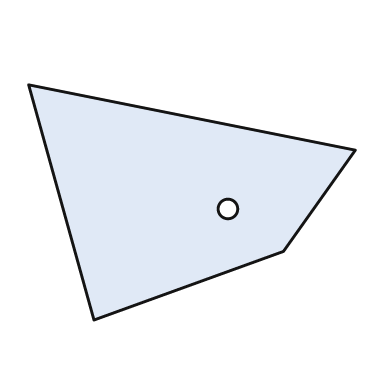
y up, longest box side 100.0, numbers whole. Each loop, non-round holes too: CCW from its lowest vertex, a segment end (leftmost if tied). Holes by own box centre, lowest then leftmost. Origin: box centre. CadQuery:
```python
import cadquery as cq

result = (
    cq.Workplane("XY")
    .moveTo(-30.0, -36.0)
    .lineTo(28.0, -15.0)
    .lineTo(50.0, 16.0)
    .lineTo(-50.0, 36.0)
    .close()
    .moveTo(11.0, -2.0)
    .circle(3.0)
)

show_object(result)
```